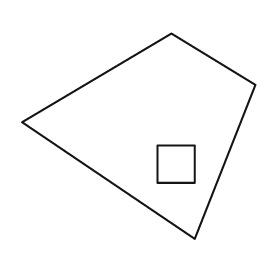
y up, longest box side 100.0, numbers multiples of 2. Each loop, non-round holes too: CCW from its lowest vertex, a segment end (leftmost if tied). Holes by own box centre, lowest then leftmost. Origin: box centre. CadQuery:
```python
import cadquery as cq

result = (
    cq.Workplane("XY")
    .moveTo(24.0, -44.0)
    .lineTo(50.0, 22.0)
    .lineTo(14.0, 44.0)
    .lineTo(-50.0, 6.0)
    .close()
    .moveTo(8.0, -20.0)
    .lineTo(24.0, -20.0)
    .lineTo(24.0, -4.0)
    .lineTo(8.0, -4.0)
    .close()
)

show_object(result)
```